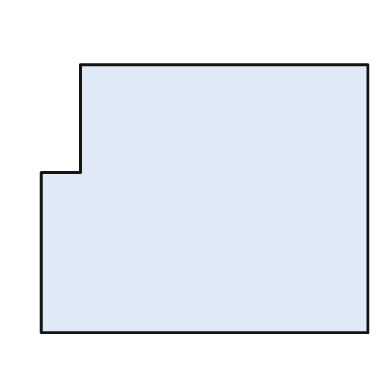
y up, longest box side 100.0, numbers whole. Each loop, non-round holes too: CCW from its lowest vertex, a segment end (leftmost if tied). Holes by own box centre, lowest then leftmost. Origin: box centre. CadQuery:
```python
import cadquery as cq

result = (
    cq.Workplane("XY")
    .moveTo(-50.0, -41.0)
    .lineTo(50.0, -41.0)
    .lineTo(50.0, 41.0)
    .lineTo(-38.0, 41.0)
    .lineTo(-38.0, 8.0)
    .lineTo(-50.0, 8.0)
    .close()
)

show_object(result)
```